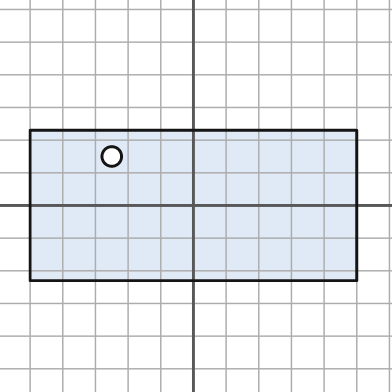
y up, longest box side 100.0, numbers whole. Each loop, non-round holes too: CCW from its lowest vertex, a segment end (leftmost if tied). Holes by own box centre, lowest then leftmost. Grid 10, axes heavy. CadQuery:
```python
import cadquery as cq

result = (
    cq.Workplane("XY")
    .moveTo(-50.0, -23.0)
    .lineTo(50.0, -23.0)
    .lineTo(50.0, 23.0)
    .lineTo(-50.0, 23.0)
    .close()
    .moveTo(-25.0, 15.0)
    .circle(3.0)
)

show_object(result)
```